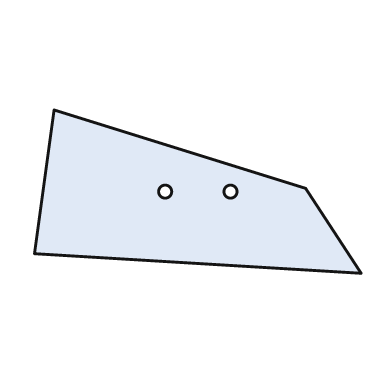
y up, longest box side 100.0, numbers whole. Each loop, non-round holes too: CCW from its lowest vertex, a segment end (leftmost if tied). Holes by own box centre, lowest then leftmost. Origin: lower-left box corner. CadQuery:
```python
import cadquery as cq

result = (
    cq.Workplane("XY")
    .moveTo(100.0, 0.0)
    .lineTo(83.0, 26.0)
    .lineTo(6.0, 50.0)
    .lineTo(0.0, 6.0)
    .close()
    .moveTo(40.0, 25.0)
    .circle(2.0)
    .moveTo(60.0, 25.0)
    .circle(2.0)
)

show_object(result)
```